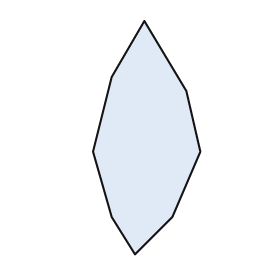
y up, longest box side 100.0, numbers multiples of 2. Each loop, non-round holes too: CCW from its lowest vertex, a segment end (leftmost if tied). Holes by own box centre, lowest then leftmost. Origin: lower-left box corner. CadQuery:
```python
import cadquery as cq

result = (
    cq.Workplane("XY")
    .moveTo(18.0, 0.0)
    .lineTo(34.0, 16.0)
    .lineTo(46.0, 44.0)
    .lineTo(40.0, 70.0)
    .lineTo(22.0, 100.0)
    .lineTo(8.0, 76.0)
    .lineTo(0.0, 44.0)
    .lineTo(8.0, 16.0)
    .close()
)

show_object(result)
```